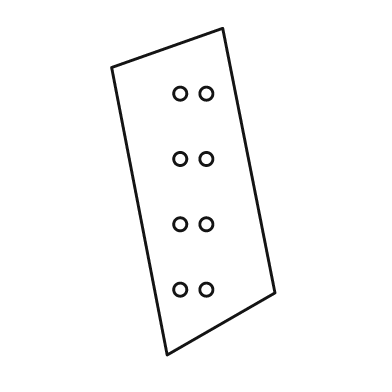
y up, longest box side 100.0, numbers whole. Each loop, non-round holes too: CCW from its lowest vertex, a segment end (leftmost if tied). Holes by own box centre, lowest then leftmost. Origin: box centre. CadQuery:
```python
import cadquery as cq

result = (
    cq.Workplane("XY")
    .moveTo(-8.0, -50.0)
    .lineTo(25.0, -31.0)
    .lineTo(9.0, 50.0)
    .lineTo(-25.0, 38.0)
    .close()
    .moveTo(-4.0, -30.0)
    .circle(2.0)
    .moveTo(4.0, -30.0)
    .circle(2.0)
    .moveTo(-4.0, -10.0)
    .circle(2.0)
    .moveTo(4.0, -10.0)
    .circle(2.0)
    .moveTo(-4.0, 10.0)
    .circle(2.0)
    .moveTo(4.0, 10.0)
    .circle(2.0)
    .moveTo(-4.0, 30.0)
    .circle(2.0)
    .moveTo(4.0, 30.0)
    .circle(2.0)
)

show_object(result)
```